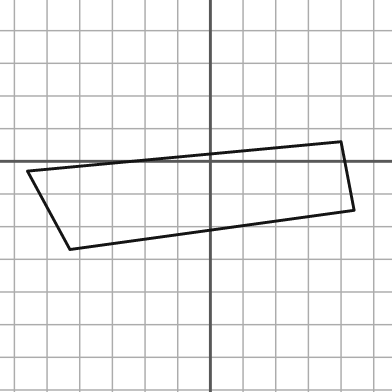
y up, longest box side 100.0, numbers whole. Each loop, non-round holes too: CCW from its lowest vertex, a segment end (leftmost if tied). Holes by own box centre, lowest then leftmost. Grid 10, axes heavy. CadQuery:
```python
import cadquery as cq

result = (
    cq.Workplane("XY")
    .moveTo(-43.0, -27.0)
    .lineTo(44.0, -15.0)
    .lineTo(40.0, 6.0)
    .lineTo(-56.0, -3.0)
    .close()
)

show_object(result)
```